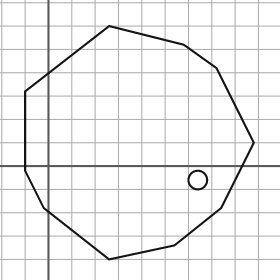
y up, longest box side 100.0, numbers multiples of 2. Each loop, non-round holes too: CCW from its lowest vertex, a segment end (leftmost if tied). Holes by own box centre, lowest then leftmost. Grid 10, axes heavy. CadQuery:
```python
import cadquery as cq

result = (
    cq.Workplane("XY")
    .moveTo(26.0, -40.0)
    .lineTo(54.0, -34.0)
    .lineTo(74.0, -18.0)
    .lineTo(88.0, 10.0)
    .lineTo(72.0, 42.0)
    .lineTo(58.0, 52.0)
    .lineTo(26.0, 60.0)
    .lineTo(-10.0, 32.0)
    .lineTo(-10.0, -2.0)
    .lineTo(-2.0, -18.0)
    .close()
    .moveTo(64.0, -6.0)
    .circle(4.0)
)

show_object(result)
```